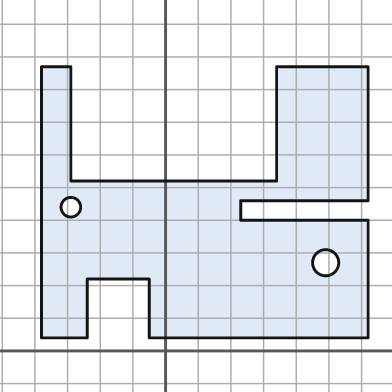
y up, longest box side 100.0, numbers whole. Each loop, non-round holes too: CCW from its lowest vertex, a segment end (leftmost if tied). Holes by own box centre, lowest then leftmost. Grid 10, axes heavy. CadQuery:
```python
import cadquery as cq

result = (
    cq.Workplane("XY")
    .moveTo(-38.0, 4.0)
    .lineTo(-24.0, 4.0)
    .lineTo(-24.0, 22.0)
    .lineTo(-5.0, 22.0)
    .lineTo(-5.0, 4.0)
    .lineTo(62.0, 4.0)
    .lineTo(62.0, 40.0)
    .lineTo(23.0, 40.0)
    .lineTo(23.0, 46.0)
    .lineTo(62.0, 46.0)
    .lineTo(62.0, 87.0)
    .lineTo(34.0, 87.0)
    .lineTo(34.0, 52.0)
    .lineTo(-29.0, 52.0)
    .lineTo(-29.0, 87.0)
    .lineTo(-38.0, 87.0)
    .close()
    .moveTo(49.0, 27.0)
    .circle(4.0)
    .moveTo(-29.0, 44.0)
    .circle(3.0)
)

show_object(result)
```